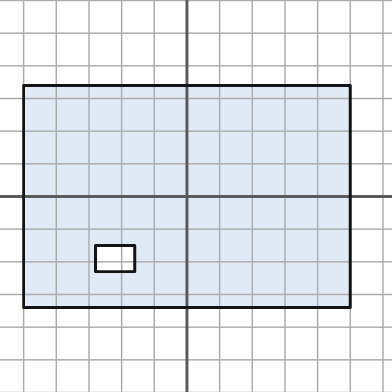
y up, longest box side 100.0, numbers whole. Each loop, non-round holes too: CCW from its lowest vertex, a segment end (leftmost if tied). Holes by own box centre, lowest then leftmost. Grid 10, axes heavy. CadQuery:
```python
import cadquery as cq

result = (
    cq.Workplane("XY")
    .moveTo(-50.0, -34.0)
    .lineTo(50.0, -34.0)
    .lineTo(50.0, 34.0)
    .lineTo(-50.0, 34.0)
    .close()
    .moveTo(-28.0, -23.0)
    .lineTo(-16.0, -23.0)
    .lineTo(-16.0, -15.0)
    .lineTo(-28.0, -15.0)
    .close()
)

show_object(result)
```